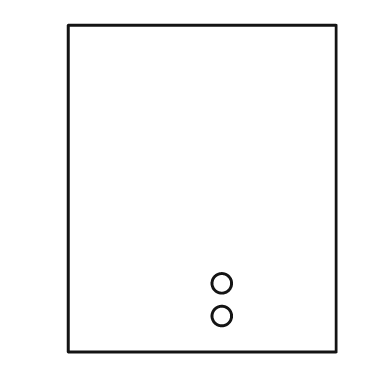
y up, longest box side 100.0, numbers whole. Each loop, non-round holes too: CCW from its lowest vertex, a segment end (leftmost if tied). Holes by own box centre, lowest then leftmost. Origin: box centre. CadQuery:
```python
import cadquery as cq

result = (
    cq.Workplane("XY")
    .moveTo(-41.0, -50.0)
    .lineTo(41.0, -50.0)
    .lineTo(41.0, 50.0)
    .lineTo(-41.0, 50.0)
    .close()
    .moveTo(6.0, -39.0)
    .circle(3.0)
    .moveTo(6.0, -29.0)
    .circle(3.0)
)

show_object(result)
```